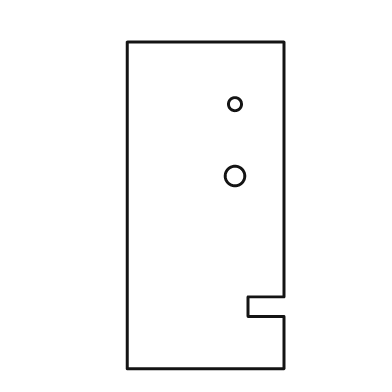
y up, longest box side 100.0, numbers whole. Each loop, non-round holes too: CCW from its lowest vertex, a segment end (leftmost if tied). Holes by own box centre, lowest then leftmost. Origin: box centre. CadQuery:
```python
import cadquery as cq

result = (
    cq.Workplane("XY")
    .moveTo(-24.0, -50.0)
    .lineTo(24.0, -50.0)
    .lineTo(24.0, -34.0)
    .lineTo(13.0, -34.0)
    .lineTo(13.0, -28.0)
    .lineTo(24.0, -28.0)
    .lineTo(24.0, 50.0)
    .lineTo(-24.0, 50.0)
    .close()
    .moveTo(9.0, 9.0)
    .circle(3.0)
    .moveTo(9.0, 31.0)
    .circle(2.0)
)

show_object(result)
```